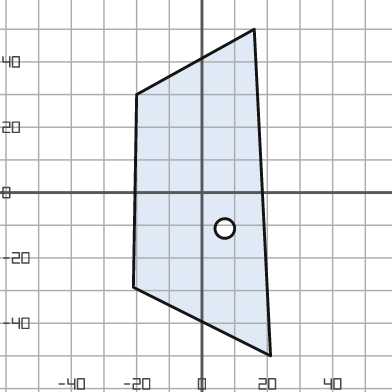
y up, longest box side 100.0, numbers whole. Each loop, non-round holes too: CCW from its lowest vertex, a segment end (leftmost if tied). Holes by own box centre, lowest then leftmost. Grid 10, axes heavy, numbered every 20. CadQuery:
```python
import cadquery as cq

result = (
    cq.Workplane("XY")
    .moveTo(21.0, -50.0)
    .lineTo(16.0, 50.0)
    .lineTo(-20.0, 30.0)
    .lineTo(-21.0, -29.0)
    .close()
    .moveTo(7.0, -11.0)
    .circle(3.0)
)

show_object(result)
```